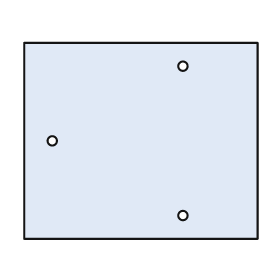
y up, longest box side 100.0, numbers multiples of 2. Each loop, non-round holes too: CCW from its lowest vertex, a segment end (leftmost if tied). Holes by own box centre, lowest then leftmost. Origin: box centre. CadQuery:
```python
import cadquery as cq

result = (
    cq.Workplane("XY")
    .moveTo(-50.0, -42.0)
    .lineTo(50.0, -42.0)
    .lineTo(50.0, 42.0)
    .lineTo(-50.0, 42.0)
    .close()
    .moveTo(18.0, -32.0)
    .circle(2.0)
    .moveTo(-38.0, 0.0)
    .circle(2.0)
    .moveTo(18.0, 32.0)
    .circle(2.0)
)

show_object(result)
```